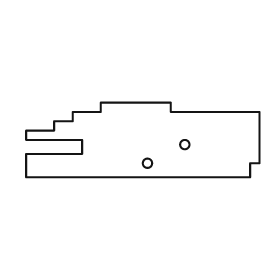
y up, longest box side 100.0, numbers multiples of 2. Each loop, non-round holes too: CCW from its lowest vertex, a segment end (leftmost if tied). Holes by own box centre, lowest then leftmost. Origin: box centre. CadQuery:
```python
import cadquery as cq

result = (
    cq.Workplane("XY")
    .moveTo(-50.0, -16.0)
    .lineTo(46.0, -16.0)
    .lineTo(46.0, -10.0)
    .lineTo(50.0, -10.0)
    .lineTo(50.0, 12.0)
    .lineTo(12.0, 12.0)
    .lineTo(12.0, 16.0)
    .lineTo(-18.0, 16.0)
    .lineTo(-18.0, 12.0)
    .lineTo(-30.0, 12.0)
    .lineTo(-30.0, 8.0)
    .lineTo(-38.0, 8.0)
    .lineTo(-38.0, 4.0)
    .lineTo(-50.0, 4.0)
    .lineTo(-50.0, 0.0)
    .lineTo(-26.0, 0.0)
    .lineTo(-26.0, -6.0)
    .lineTo(-50.0, -6.0)
    .close()
    .moveTo(2.0, -10.0)
    .circle(2.0)
    .moveTo(18.0, -2.0)
    .circle(2.0)
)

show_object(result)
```